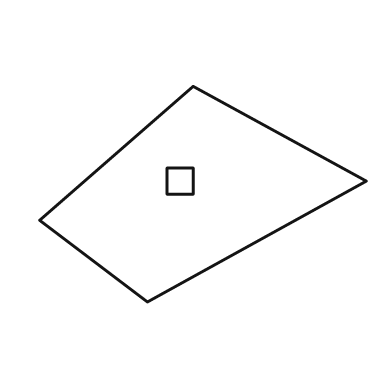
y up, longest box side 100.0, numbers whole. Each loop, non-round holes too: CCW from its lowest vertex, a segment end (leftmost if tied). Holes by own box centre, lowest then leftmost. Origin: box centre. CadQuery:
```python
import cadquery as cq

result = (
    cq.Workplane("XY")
    .moveTo(-17.0, -33.0)
    .lineTo(50.0, 4.0)
    .lineTo(-3.0, 33.0)
    .lineTo(-50.0, -8.0)
    .close()
    .moveTo(-11.0, 0.0)
    .lineTo(-3.0, 0.0)
    .lineTo(-3.0, 8.0)
    .lineTo(-11.0, 8.0)
    .close()
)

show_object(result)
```